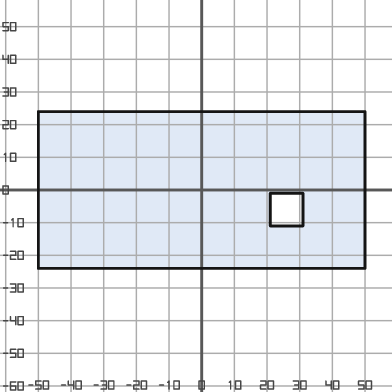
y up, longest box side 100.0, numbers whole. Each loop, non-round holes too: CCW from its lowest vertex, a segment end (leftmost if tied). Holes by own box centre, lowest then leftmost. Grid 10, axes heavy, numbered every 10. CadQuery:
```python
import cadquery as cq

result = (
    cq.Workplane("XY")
    .moveTo(-50.0, -24.0)
    .lineTo(50.0, -24.0)
    .lineTo(50.0, 24.0)
    .lineTo(-50.0, 24.0)
    .close()
    .moveTo(21.0, -11.0)
    .lineTo(31.0, -11.0)
    .lineTo(31.0, -1.0)
    .lineTo(21.0, -1.0)
    .close()
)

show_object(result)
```